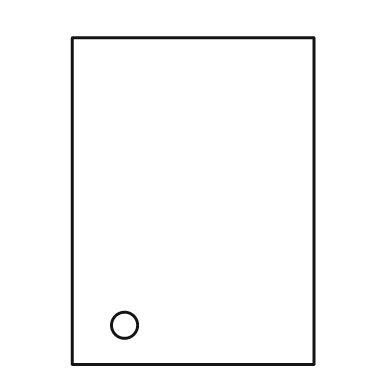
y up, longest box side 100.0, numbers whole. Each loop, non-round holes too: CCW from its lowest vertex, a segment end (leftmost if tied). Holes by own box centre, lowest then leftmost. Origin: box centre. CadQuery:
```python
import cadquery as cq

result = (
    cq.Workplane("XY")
    .moveTo(-37.0, -50.0)
    .lineTo(37.0, -50.0)
    .lineTo(37.0, 50.0)
    .lineTo(-37.0, 50.0)
    .close()
    .moveTo(-21.0, -38.0)
    .circle(4.0)
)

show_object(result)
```